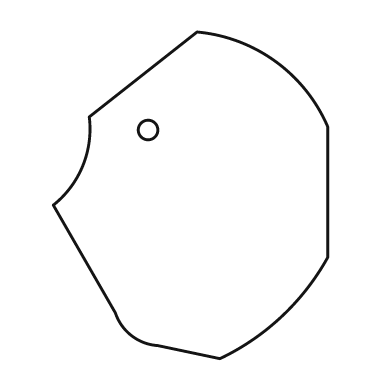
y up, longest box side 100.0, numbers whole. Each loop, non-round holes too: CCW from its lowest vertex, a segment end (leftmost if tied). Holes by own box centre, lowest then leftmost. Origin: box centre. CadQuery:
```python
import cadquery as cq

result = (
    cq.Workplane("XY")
    .moveTo(9.0, -50.0)
    .threePointArc((28.0, -37.0), (42.0, -19.0))
    .lineTo(42.0, 21.0)
    .threePointArc((26.0, 41.0), (2.0, 50.0))
    .lineTo(-31.0, 24.0)
    .threePointArc((-33.0, 9.0), (-42.0, -3.0))
    .lineTo(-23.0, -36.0)
    .threePointArc((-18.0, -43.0), (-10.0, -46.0))
    .close()
    .moveTo(-13.0, 20.0)
    .circle(3.0)
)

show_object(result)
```